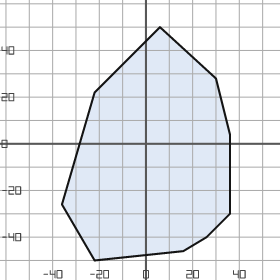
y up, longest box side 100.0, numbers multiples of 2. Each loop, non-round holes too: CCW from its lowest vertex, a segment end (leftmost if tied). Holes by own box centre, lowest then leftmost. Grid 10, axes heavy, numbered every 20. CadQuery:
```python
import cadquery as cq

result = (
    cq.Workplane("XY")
    .moveTo(-22.0, -50.0)
    .lineTo(16.0, -46.0)
    .lineTo(26.0, -40.0)
    .lineTo(36.0, -30.0)
    .lineTo(36.0, 4.0)
    .lineTo(30.0, 28.0)
    .lineTo(6.0, 50.0)
    .lineTo(-22.0, 22.0)
    .lineTo(-36.0, -26.0)
    .close()
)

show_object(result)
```